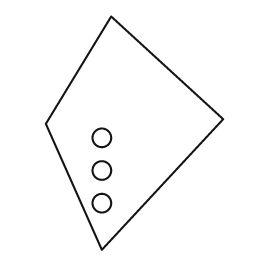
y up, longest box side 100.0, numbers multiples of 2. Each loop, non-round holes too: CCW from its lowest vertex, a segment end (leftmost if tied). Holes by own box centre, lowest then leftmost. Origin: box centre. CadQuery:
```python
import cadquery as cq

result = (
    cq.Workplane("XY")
    .moveTo(-14.0, -50.0)
    .lineTo(38.0, 6.0)
    .lineTo(-10.0, 50.0)
    .lineTo(-38.0, 4.0)
    .close()
    .moveTo(-14.0, -30.0)
    .circle(4.0)
    .moveTo(-14.0, -16.0)
    .circle(4.0)
    .moveTo(-14.0, -2.0)
    .circle(4.0)
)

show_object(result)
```